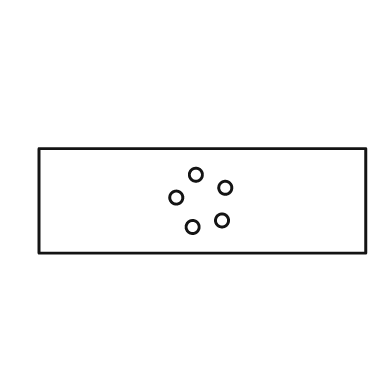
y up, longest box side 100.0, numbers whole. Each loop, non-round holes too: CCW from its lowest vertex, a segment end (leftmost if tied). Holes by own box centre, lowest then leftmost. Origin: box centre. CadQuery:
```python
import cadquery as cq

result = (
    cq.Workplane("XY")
    .moveTo(-50.0, -16.0)
    .lineTo(50.0, -16.0)
    .lineTo(50.0, 16.0)
    .lineTo(-50.0, 16.0)
    .close()
    .moveTo(-3.0, -8.0)
    .circle(2.0)
    .moveTo(6.0, -6.0)
    .circle(2.0)
    .moveTo(-8.0, 1.0)
    .circle(2.0)
    .moveTo(7.0, 4.0)
    .circle(2.0)
    .moveTo(-2.0, 8.0)
    .circle(2.0)
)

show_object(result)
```